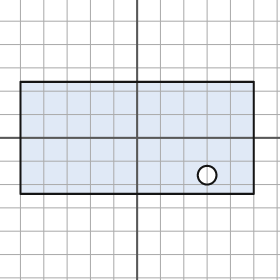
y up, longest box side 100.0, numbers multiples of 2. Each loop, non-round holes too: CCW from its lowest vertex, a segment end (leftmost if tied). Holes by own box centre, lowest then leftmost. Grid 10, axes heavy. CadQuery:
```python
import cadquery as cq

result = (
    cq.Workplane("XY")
    .moveTo(-50.0, -24.0)
    .lineTo(50.0, -24.0)
    .lineTo(50.0, 24.0)
    .lineTo(-50.0, 24.0)
    .close()
    .moveTo(30.0, -16.0)
    .circle(4.0)
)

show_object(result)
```